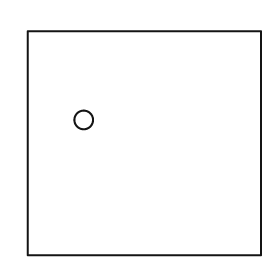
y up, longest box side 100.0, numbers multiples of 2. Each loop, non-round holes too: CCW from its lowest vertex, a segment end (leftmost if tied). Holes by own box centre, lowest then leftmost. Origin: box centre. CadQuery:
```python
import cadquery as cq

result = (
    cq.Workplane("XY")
    .moveTo(-50.0, -48.0)
    .lineTo(50.0, -48.0)
    .lineTo(50.0, 48.0)
    .lineTo(-50.0, 48.0)
    .close()
    .moveTo(-26.0, 10.0)
    .circle(4.0)
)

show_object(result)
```